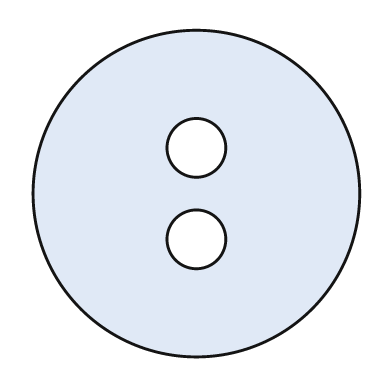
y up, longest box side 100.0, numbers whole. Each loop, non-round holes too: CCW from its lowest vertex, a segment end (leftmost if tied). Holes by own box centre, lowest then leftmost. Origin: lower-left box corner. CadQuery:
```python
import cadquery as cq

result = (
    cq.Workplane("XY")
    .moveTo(50.0, 50.0)
    .circle(50.0)
    .moveTo(50.0, 36.0)
    .circle(9.0)
    .moveTo(50.0, 64.0)
    .circle(9.0)
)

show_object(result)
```